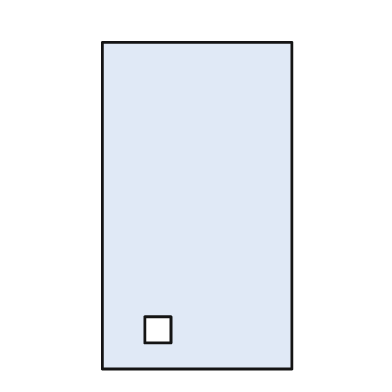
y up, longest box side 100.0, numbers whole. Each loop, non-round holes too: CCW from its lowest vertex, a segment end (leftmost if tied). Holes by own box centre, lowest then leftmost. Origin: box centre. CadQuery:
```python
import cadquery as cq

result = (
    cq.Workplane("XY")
    .moveTo(-29.0, -50.0)
    .lineTo(29.0, -50.0)
    .lineTo(29.0, 50.0)
    .lineTo(-29.0, 50.0)
    .close()
    .moveTo(-16.0, -42.0)
    .lineTo(-8.0, -42.0)
    .lineTo(-8.0, -34.0)
    .lineTo(-16.0, -34.0)
    .close()
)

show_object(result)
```